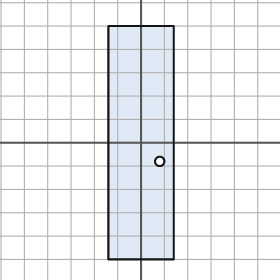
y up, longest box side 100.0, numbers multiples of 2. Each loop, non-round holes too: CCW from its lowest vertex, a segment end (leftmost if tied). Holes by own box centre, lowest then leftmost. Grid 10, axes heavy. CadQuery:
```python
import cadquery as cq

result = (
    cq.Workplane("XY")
    .moveTo(-14.0, -50.0)
    .lineTo(14.0, -50.0)
    .lineTo(14.0, 50.0)
    .lineTo(-14.0, 50.0)
    .close()
    .moveTo(8.0, -8.0)
    .circle(2.0)
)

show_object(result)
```